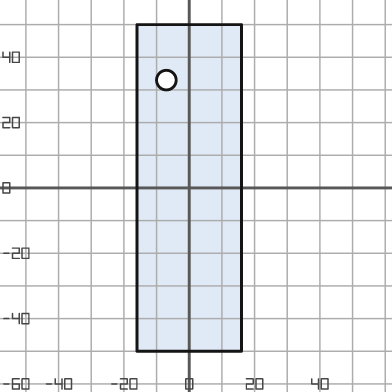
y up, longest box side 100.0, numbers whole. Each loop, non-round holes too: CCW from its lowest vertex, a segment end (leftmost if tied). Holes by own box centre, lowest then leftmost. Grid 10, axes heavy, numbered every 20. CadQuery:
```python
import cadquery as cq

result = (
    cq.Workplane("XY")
    .moveTo(-16.0, -50.0)
    .lineTo(16.0, -50.0)
    .lineTo(16.0, 50.0)
    .lineTo(-16.0, 50.0)
    .close()
    .moveTo(-7.0, 33.0)
    .circle(3.0)
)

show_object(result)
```